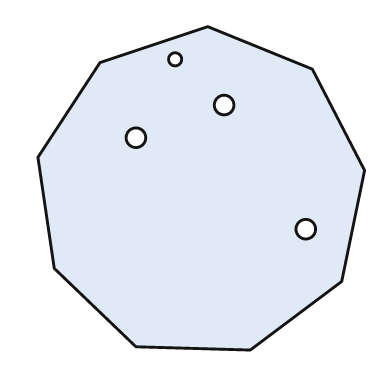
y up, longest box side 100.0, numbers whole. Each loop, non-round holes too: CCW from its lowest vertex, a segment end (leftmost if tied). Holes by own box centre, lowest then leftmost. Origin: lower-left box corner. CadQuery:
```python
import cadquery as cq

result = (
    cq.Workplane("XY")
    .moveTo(65.0, 0.0)
    .lineTo(93.0, 21.0)
    .lineTo(100.0, 55.0)
    .lineTo(84.0, 86.0)
    .lineTo(52.0, 99.0)
    .lineTo(19.0, 88.0)
    .lineTo(0.0, 59.0)
    .lineTo(5.0, 25.0)
    .lineTo(30.0, 1.0)
    .close()
    .moveTo(82.0, 37.0)
    .circle(3.0)
    .moveTo(30.0, 65.0)
    .circle(3.0)
    .moveTo(57.0, 75.0)
    .circle(3.0)
    .moveTo(42.0, 89.0)
    .circle(2.0)
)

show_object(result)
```